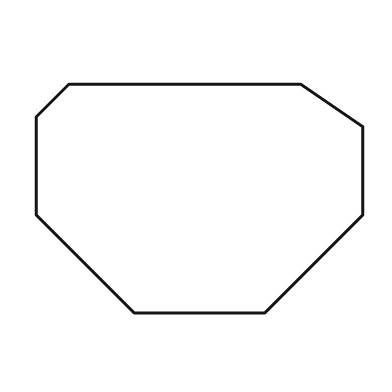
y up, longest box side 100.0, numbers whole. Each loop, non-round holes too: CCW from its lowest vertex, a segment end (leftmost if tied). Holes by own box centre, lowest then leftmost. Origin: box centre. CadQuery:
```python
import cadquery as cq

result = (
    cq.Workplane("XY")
    .moveTo(-20.0, -35.0)
    .lineTo(20.0, -35.0)
    .lineTo(50.0, -5.0)
    .lineTo(50.0, 22.0)
    .lineTo(31.0, 35.0)
    .lineTo(-40.0, 35.0)
    .lineTo(-50.0, 25.0)
    .lineTo(-50.0, -5.0)
    .close()
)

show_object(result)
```